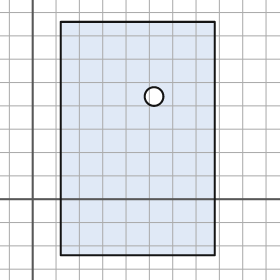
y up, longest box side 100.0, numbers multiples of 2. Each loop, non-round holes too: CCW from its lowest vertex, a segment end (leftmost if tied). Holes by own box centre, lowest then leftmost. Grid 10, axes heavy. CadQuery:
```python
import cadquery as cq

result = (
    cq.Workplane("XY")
    .moveTo(12.0, -24.0)
    .lineTo(78.0, -24.0)
    .lineTo(78.0, 76.0)
    .lineTo(12.0, 76.0)
    .close()
    .moveTo(52.0, 44.0)
    .circle(4.0)
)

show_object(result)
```